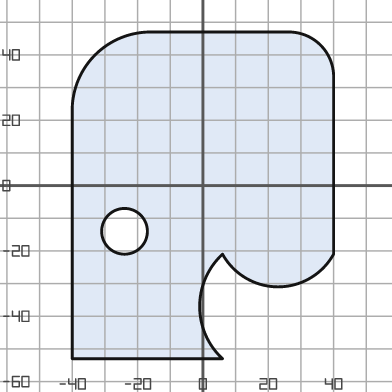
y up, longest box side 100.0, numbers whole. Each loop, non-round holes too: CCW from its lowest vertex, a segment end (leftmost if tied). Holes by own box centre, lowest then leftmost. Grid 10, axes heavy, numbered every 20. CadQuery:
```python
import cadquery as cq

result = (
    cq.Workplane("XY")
    .moveTo(-40.0, -53.0)
    .lineTo(6.0, -53.0)
    .threePointArc((-1.0, -37.0), (6.0, -21.0))
    .threePointArc((23.0, -31.0), (40.0, -21.0))
    .lineTo(40.0, 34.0)
    .threePointArc((36.0, 43.0), (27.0, 47.0))
    .lineTo(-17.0, 47.0)
    .threePointArc((-33.0, 40.0), (-40.0, 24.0))
    .close()
    .moveTo(-24.0, -14.0)
    .circle(7.0)
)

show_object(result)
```